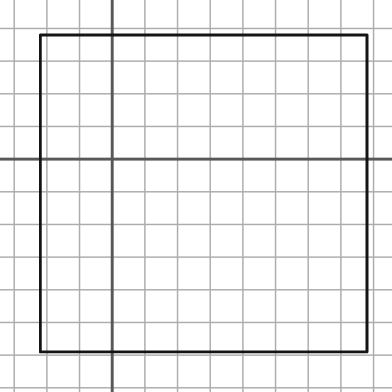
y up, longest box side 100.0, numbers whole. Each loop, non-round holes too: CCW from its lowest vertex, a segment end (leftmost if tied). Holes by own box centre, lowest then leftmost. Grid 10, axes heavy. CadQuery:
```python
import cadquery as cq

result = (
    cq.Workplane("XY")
    .moveTo(-22.0, -59.0)
    .lineTo(78.0, -59.0)
    .lineTo(78.0, 38.0)
    .lineTo(-22.0, 38.0)
    .close()
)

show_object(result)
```